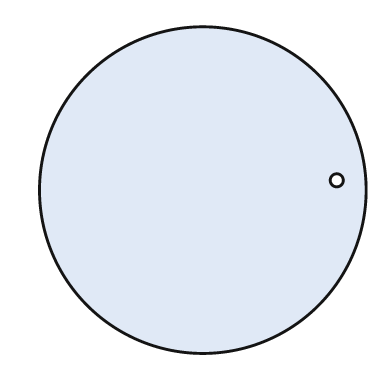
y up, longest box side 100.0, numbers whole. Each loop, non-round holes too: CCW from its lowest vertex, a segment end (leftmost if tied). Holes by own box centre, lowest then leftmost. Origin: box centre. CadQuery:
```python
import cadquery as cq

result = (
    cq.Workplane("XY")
    .moveTo(0.0, 0.0)
    .circle(50.0)
    .moveTo(41.0, 3.0)
    .circle(2.0)
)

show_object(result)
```